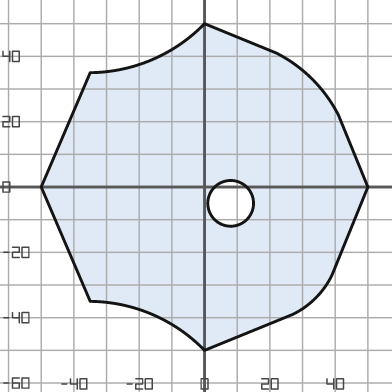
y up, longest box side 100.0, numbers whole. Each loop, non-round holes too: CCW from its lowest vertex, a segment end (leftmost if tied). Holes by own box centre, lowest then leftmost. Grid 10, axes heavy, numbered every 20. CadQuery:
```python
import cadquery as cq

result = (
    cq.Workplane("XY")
    .moveTo(0.0, -50.0)
    .lineTo(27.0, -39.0)
    .threePointArc((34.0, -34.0), (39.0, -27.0))
    .lineTo(50.0, 0.0)
    .lineTo(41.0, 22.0)
    .threePointArc((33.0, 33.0), (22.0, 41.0))
    .lineTo(0.0, 50.0)
    .threePointArc((-16.0, 39.0), (-35.0, 35.0))
    .lineTo(-50.0, 0.0)
    .lineTo(-35.0, -35.0)
    .threePointArc((-16.0, -39.0), (0.0, -50.0))
    .close()
    .moveTo(8.0, -5.0)
    .circle(7.0)
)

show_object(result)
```